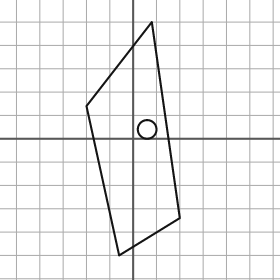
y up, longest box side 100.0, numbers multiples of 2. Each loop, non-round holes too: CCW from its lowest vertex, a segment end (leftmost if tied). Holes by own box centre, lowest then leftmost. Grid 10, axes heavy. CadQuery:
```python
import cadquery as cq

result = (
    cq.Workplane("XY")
    .moveTo(-6.0, -50.0)
    .lineTo(20.0, -34.0)
    .lineTo(8.0, 50.0)
    .lineTo(-20.0, 14.0)
    .close()
    .moveTo(6.0, 4.0)
    .circle(4.0)
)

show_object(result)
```